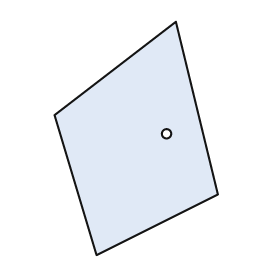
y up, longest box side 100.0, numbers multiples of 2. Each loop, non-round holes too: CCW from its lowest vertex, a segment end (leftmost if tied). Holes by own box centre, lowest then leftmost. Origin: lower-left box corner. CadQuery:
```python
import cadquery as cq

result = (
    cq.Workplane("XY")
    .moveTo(18.0, 0.0)
    .lineTo(70.0, 26.0)
    .lineTo(52.0, 100.0)
    .lineTo(0.0, 60.0)
    .close()
    .moveTo(48.0, 52.0)
    .circle(2.0)
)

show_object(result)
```